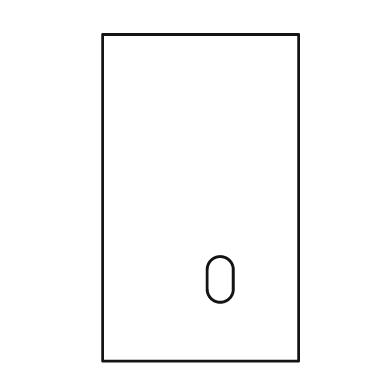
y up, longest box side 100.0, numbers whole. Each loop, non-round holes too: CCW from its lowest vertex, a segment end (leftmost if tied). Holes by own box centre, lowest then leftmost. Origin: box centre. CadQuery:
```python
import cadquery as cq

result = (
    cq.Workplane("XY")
    .moveTo(-30.0, -50.0)
    .lineTo(30.0, -50.0)
    .lineTo(30.0, 50.0)
    .lineTo(-30.0, 50.0)
    .close()
    .moveTo(2.0, -28.0)
    .threePointArc((6.0, -32.0), (10.0, -28.0))
    .lineTo(10.0, -22.0)
    .threePointArc((6.0, -18.0), (2.0, -22.0))
    .close()
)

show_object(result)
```